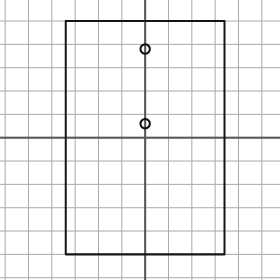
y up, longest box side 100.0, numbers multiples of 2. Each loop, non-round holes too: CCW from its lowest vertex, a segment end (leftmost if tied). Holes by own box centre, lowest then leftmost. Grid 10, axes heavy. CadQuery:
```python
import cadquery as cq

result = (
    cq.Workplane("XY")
    .moveTo(-34.0, -50.0)
    .lineTo(34.0, -50.0)
    .lineTo(34.0, 50.0)
    .lineTo(-34.0, 50.0)
    .close()
    .moveTo(0.0, 6.0)
    .circle(2.0)
    .moveTo(0.0, 38.0)
    .circle(2.0)
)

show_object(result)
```